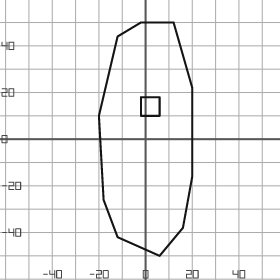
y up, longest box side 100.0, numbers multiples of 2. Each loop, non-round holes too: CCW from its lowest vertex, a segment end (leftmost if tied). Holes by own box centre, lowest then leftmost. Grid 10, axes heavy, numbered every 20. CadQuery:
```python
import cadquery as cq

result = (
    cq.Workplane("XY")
    .moveTo(6.0, -50.0)
    .lineTo(16.0, -38.0)
    .lineTo(20.0, -16.0)
    .lineTo(20.0, 22.0)
    .lineTo(12.0, 50.0)
    .lineTo(-2.0, 50.0)
    .lineTo(-12.0, 44.0)
    .lineTo(-20.0, 10.0)
    .lineTo(-18.0, -26.0)
    .lineTo(-12.0, -42.0)
    .close()
    .moveTo(-2.0, 10.0)
    .lineTo(6.0, 10.0)
    .lineTo(6.0, 18.0)
    .lineTo(-2.0, 18.0)
    .close()
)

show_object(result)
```